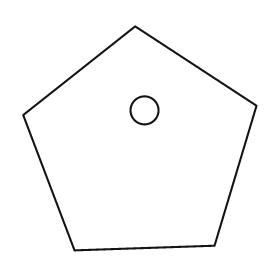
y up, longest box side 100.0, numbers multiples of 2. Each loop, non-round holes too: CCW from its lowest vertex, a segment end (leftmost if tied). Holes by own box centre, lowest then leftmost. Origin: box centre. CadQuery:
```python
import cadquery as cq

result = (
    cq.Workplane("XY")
    .moveTo(-28.0, -48.0)
    .lineTo(32.0, -46.0)
    .lineTo(50.0, 14.0)
    .lineTo(-2.0, 48.0)
    .lineTo(-50.0, 10.0)
    .close()
    .moveTo(2.0, 12.0)
    .circle(6.0)
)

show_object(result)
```